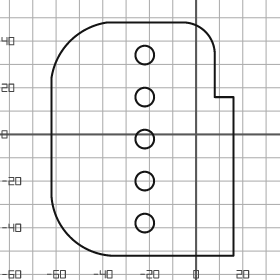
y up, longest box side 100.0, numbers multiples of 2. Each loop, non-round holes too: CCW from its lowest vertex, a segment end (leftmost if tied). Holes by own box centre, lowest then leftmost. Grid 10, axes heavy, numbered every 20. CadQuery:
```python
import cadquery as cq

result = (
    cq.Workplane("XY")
    .moveTo(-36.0, -52.0)
    .lineTo(16.0, -52.0)
    .lineTo(16.0, 16.0)
    .lineTo(8.0, 16.0)
    .lineTo(8.0, 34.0)
    .threePointArc((4.0, 44.0), (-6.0, 48.0))
    .lineTo(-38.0, 48.0)
    .threePointArc((-54.0, 40.0), (-62.0, 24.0))
    .lineTo(-62.0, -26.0)
    .threePointArc((-54.0, -44.0), (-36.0, -52.0))
    .close()
    .moveTo(-22.0, -38.0)
    .circle(4.0)
    .moveTo(-22.0, -20.0)
    .circle(4.0)
    .moveTo(-22.0, -2.0)
    .circle(4.0)
    .moveTo(-22.0, 16.0)
    .circle(4.0)
    .moveTo(-22.0, 34.0)
    .circle(4.0)
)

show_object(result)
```